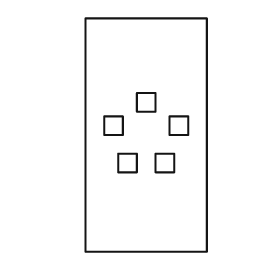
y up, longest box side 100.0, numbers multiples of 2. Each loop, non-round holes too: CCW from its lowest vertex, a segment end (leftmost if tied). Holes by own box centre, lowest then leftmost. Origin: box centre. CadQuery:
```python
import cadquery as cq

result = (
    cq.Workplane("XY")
    .moveTo(-26.0, -50.0)
    .lineTo(26.0, -50.0)
    .lineTo(26.0, 50.0)
    .lineTo(-26.0, 50.0)
    .close()
    .moveTo(-12.0, -16.0)
    .lineTo(-4.0, -16.0)
    .lineTo(-4.0, -8.0)
    .lineTo(-12.0, -8.0)
    .close()
    .moveTo(4.0, -16.0)
    .lineTo(12.0, -16.0)
    .lineTo(12.0, -8.0)
    .lineTo(4.0, -8.0)
    .close()
    .moveTo(-18.0, 0.0)
    .lineTo(-10.0, 0.0)
    .lineTo(-10.0, 8.0)
    .lineTo(-18.0, 8.0)
    .close()
    .moveTo(10.0, 0.0)
    .lineTo(18.0, 0.0)
    .lineTo(18.0, 8.0)
    .lineTo(10.0, 8.0)
    .close()
    .moveTo(-4.0, 10.0)
    .lineTo(4.0, 10.0)
    .lineTo(4.0, 18.0)
    .lineTo(-4.0, 18.0)
    .close()
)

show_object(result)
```